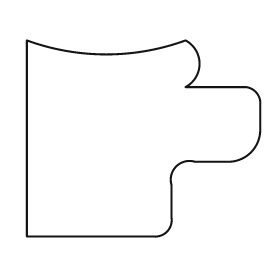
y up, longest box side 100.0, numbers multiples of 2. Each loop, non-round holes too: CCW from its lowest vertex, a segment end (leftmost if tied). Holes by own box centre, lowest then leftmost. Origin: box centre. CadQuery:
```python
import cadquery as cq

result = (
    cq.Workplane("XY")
    .moveTo(-50.0, -42.0)
    .lineTo(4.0, -42.0)
    .threePointArc((10.0, -40.0), (12.0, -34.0))
    .lineTo(12.0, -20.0)
    .threePointArc((14.0, -12.0), (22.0, -10.0))
    .lineTo(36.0, -10.0)
    .threePointArc((46.0, -6.0), (50.0, 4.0))
    .lineTo(50.0, 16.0)
    .threePointArc((48.0, 20.0), (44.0, 22.0))
    .lineTo(18.0, 22.0)
    .threePointArc((24.0, 32.0), (18.0, 42.0))
    .threePointArc((-16.0, 36.0), (-50.0, 42.0))
    .close()
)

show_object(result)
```